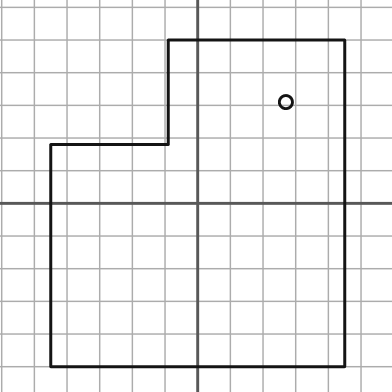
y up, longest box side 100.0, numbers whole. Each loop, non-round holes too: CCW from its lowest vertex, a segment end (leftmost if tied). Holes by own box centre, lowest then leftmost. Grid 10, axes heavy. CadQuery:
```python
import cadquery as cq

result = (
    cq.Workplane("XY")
    .moveTo(-45.0, -50.0)
    .lineTo(45.0, -50.0)
    .lineTo(45.0, 50.0)
    .lineTo(-9.0, 50.0)
    .lineTo(-9.0, 18.0)
    .lineTo(-45.0, 18.0)
    .close()
    .moveTo(27.0, 31.0)
    .circle(2.0)
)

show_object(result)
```